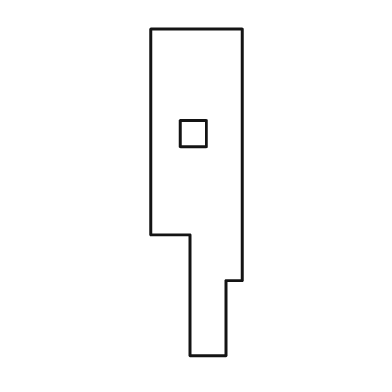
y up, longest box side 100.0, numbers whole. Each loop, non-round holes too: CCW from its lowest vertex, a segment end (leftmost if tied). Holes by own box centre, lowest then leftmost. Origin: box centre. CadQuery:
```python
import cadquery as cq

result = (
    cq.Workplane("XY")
    .moveTo(-2.0, -50.0)
    .lineTo(9.0, -50.0)
    .lineTo(9.0, -27.0)
    .lineTo(14.0, -27.0)
    .lineTo(14.0, 50.0)
    .lineTo(-14.0, 50.0)
    .lineTo(-14.0, -13.0)
    .lineTo(-2.0, -13.0)
    .close()
    .moveTo(-5.0, 14.0)
    .lineTo(3.0, 14.0)
    .lineTo(3.0, 22.0)
    .lineTo(-5.0, 22.0)
    .close()
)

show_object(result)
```